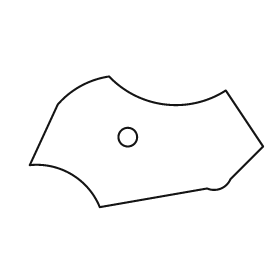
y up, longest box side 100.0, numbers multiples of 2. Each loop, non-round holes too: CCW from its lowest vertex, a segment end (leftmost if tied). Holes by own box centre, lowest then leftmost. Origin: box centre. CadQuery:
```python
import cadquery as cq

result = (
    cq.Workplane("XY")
    .moveTo(-20.0, -28.0)
    .lineTo(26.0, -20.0)
    .threePointArc((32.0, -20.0), (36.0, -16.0))
    .lineTo(50.0, -2.0)
    .lineTo(34.0, 22.0)
    .threePointArc((8.0, 16.0), (-16.0, 28.0))
    .threePointArc((-28.0, 24.0), (-38.0, 16.0))
    .lineTo(-50.0, -10.0)
    .threePointArc((-32.0, -14.0), (-20.0, -28.0))
    .close()
    .moveTo(-8.0, 2.0)
    .circle(4.0)
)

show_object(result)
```